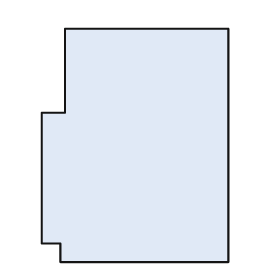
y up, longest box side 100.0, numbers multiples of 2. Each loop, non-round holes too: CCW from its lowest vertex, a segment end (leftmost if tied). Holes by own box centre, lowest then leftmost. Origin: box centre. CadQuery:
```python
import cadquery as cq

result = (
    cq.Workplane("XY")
    .moveTo(-32.0, -50.0)
    .lineTo(40.0, -50.0)
    .lineTo(40.0, 50.0)
    .lineTo(-30.0, 50.0)
    .lineTo(-30.0, 14.0)
    .lineTo(-40.0, 14.0)
    .lineTo(-40.0, -42.0)
    .lineTo(-32.0, -42.0)
    .close()
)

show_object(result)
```